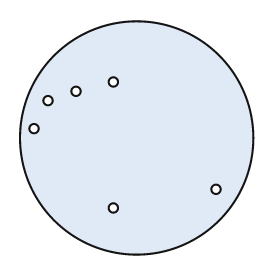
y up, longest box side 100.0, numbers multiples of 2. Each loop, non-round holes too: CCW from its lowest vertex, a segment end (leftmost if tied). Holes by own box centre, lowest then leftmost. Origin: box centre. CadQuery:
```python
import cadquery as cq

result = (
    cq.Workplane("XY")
    .moveTo(0.0, 0.0)
    .circle(50.0)
    .moveTo(-10.0, -30.0)
    .circle(2.0)
    .moveTo(34.0, -22.0)
    .circle(2.0)
    .moveTo(-44.0, 4.0)
    .circle(2.0)
    .moveTo(-38.0, 16.0)
    .circle(2.0)
    .moveTo(-26.0, 20.0)
    .circle(2.0)
    .moveTo(-10.0, 24.0)
    .circle(2.0)
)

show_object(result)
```